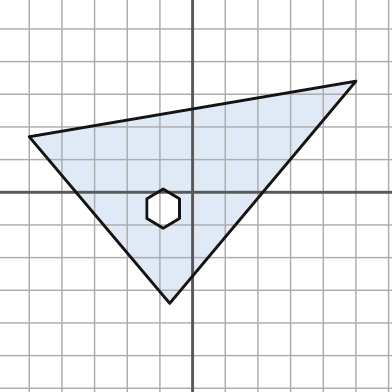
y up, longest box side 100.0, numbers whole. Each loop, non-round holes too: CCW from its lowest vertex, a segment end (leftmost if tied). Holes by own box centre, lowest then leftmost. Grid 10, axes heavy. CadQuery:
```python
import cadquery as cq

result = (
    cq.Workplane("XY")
    .moveTo(-7.0, -34.0)
    .lineTo(50.0, 34.0)
    .lineTo(-50.0, 17.0)
    .close()
    .moveTo(-9.0, -11.0)
    .lineTo(-4.0, -8.0)
    .lineTo(-4.0, -2.0)
    .lineTo(-9.0, 1.0)
    .lineTo(-14.0, -2.0)
    .lineTo(-14.0, -8.0)
    .close()
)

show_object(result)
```